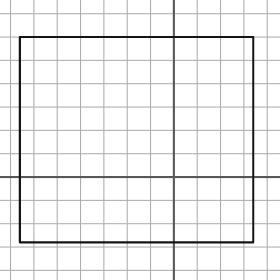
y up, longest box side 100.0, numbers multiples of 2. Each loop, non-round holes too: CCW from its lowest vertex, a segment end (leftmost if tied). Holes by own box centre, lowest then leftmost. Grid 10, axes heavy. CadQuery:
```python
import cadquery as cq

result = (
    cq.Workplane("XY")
    .moveTo(-66.0, -28.0)
    .lineTo(34.0, -28.0)
    .lineTo(34.0, 60.0)
    .lineTo(-66.0, 60.0)
    .close()
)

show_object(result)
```